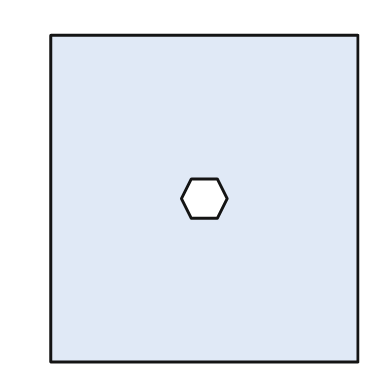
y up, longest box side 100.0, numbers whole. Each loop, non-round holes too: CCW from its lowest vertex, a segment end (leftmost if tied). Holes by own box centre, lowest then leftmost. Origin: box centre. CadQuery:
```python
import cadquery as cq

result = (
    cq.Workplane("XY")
    .moveTo(-47.0, -50.0)
    .lineTo(47.0, -50.0)
    .lineTo(47.0, 50.0)
    .lineTo(-47.0, 50.0)
    .close()
    .moveTo(-4.0, -6.0)
    .lineTo(4.0, -6.0)
    .lineTo(7.0, 0.0)
    .lineTo(4.0, 6.0)
    .lineTo(-4.0, 6.0)
    .lineTo(-7.0, 0.0)
    .close()
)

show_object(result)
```